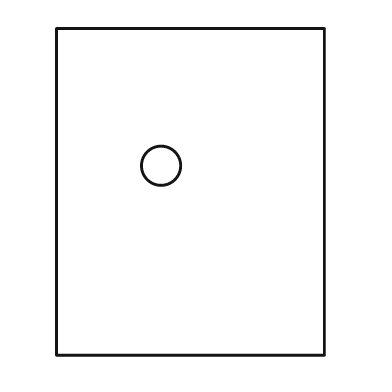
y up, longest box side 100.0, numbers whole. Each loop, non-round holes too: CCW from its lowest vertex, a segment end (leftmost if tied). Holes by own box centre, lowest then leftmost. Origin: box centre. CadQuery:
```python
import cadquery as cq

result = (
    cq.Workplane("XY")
    .moveTo(-41.0, -50.0)
    .lineTo(41.0, -50.0)
    .lineTo(41.0, 50.0)
    .lineTo(-41.0, 50.0)
    .close()
    .moveTo(-9.0, 8.0)
    .circle(6.0)
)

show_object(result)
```